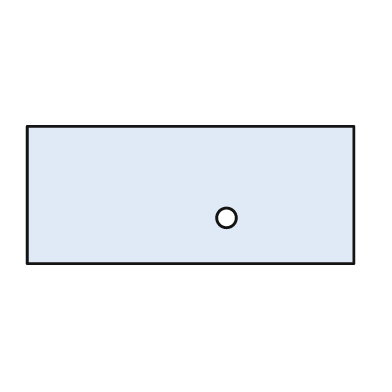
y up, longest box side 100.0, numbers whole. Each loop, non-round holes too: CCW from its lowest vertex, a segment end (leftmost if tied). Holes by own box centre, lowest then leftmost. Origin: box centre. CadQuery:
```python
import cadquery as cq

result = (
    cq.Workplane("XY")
    .moveTo(-50.0, -21.0)
    .lineTo(50.0, -21.0)
    .lineTo(50.0, 21.0)
    .lineTo(-50.0, 21.0)
    .close()
    .moveTo(11.0, -7.0)
    .circle(3.0)
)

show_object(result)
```